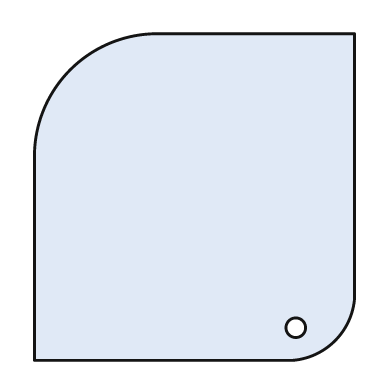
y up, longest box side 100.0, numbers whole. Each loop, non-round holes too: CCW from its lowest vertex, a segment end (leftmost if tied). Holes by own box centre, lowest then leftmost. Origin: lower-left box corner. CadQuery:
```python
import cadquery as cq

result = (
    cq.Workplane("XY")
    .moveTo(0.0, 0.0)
    .lineTo(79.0, 0.0)
    .threePointArc((92.0, 6.0), (98.0, 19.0))
    .lineTo(98.0, 100.0)
    .lineTo(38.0, 100.0)
    .threePointArc((11.0, 89.0), (0.0, 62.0))
    .close()
    .moveTo(80.0, 10.0)
    .circle(3.0)
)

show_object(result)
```